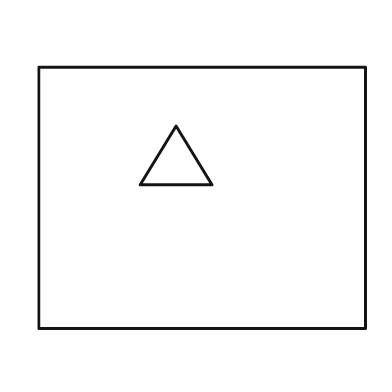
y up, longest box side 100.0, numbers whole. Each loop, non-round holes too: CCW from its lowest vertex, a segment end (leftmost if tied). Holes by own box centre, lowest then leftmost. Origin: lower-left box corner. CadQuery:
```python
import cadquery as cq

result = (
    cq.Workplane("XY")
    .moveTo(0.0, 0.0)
    .lineTo(100.0, 0.0)
    .lineTo(100.0, 80.0)
    .lineTo(0.0, 80.0)
    .close()
    .moveTo(31.0, 44.0)
    .lineTo(53.0, 44.0)
    .lineTo(42.0, 62.0)
    .close()
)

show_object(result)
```